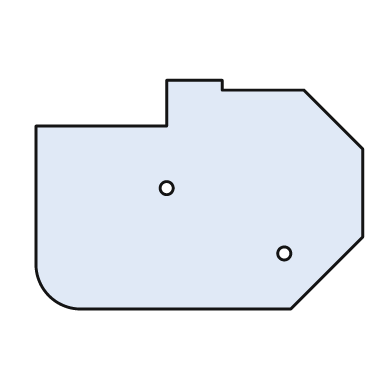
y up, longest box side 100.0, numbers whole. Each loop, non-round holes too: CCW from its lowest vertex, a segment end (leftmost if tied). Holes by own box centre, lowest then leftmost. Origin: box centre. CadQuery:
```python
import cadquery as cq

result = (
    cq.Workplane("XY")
    .moveTo(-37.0, -35.0)
    .lineTo(28.0, -35.0)
    .lineTo(50.0, -13.0)
    .lineTo(50.0, 14.0)
    .lineTo(32.0, 32.0)
    .lineTo(7.0, 32.0)
    .lineTo(7.0, 35.0)
    .lineTo(-10.0, 35.0)
    .lineTo(-10.0, 21.0)
    .lineTo(-50.0, 21.0)
    .lineTo(-50.0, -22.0)
    .threePointArc((-46.0, -31.0), (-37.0, -35.0))
    .close()
    .moveTo(26.0, -18.0)
    .circle(2.0)
    .moveTo(-10.0, 2.0)
    .circle(2.0)
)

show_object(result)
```